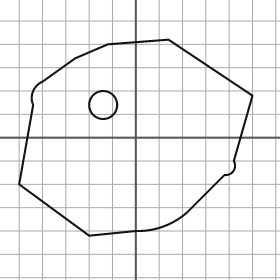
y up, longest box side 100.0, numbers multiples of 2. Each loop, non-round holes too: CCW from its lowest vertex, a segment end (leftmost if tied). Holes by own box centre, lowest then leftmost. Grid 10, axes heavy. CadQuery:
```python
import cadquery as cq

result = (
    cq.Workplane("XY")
    .moveTo(-20.0, -42.0)
    .lineTo(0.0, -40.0)
    .threePointArc((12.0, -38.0), (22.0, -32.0))
    .lineTo(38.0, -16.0)
    .threePointArc((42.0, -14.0), (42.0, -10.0))
    .lineTo(50.0, 18.0)
    .lineTo(14.0, 42.0)
    .lineTo(-12.0, 40.0)
    .lineTo(-26.0, 34.0)
    .lineTo(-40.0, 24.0)
    .threePointArc((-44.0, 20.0), (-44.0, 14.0))
    .lineTo(-50.0, -20.0)
    .close()
    .moveTo(-14.0, 14.0)
    .circle(6.0)
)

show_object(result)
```